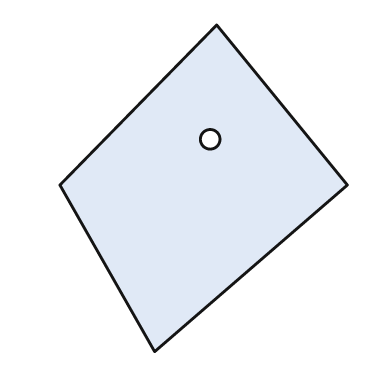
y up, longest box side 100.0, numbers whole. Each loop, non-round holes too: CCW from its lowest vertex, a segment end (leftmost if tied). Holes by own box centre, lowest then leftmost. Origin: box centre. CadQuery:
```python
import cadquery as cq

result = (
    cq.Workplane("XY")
    .moveTo(-15.0, -50.0)
    .lineTo(44.0, 1.0)
    .lineTo(4.0, 50.0)
    .lineTo(-44.0, 1.0)
    .close()
    .moveTo(2.0, 15.0)
    .circle(3.0)
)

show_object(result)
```